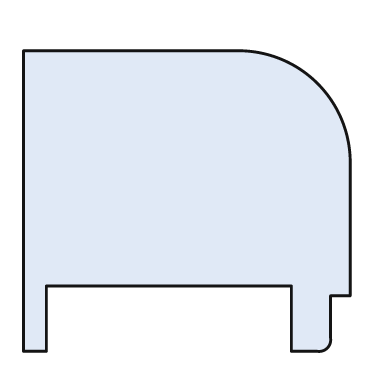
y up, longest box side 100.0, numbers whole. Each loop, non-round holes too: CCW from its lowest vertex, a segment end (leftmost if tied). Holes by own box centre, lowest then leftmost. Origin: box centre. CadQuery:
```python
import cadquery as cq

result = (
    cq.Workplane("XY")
    .moveTo(-50.0, -46.0)
    .lineTo(-43.0, -46.0)
    .lineTo(-43.0, -26.0)
    .lineTo(32.0, -26.0)
    .lineTo(32.0, -46.0)
    .lineTo(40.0, -46.0)
    .threePointArc((43.0, -45.0), (44.0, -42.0))
    .lineTo(44.0, -29.0)
    .lineTo(50.0, -29.0)
    .lineTo(50.0, 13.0)
    .threePointArc((40.0, 36.0), (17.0, 46.0))
    .lineTo(-50.0, 46.0)
    .close()
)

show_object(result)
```